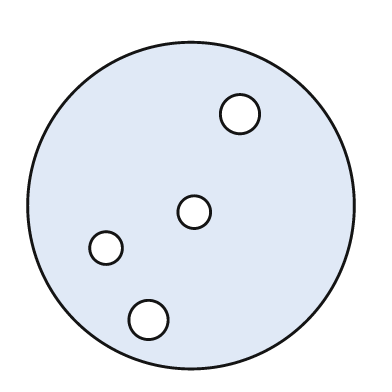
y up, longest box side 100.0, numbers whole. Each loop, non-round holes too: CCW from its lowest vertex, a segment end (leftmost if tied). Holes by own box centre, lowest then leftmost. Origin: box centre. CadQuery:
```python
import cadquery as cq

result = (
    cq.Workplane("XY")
    .moveTo(0.0, 0.0)
    .circle(50.0)
    .moveTo(-13.0, -35.0)
    .circle(6.0)
    .moveTo(-26.0, -13.0)
    .circle(5.0)
    .moveTo(1.0, -2.0)
    .circle(5.0)
    .moveTo(15.0, 28.0)
    .circle(6.0)
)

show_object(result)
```